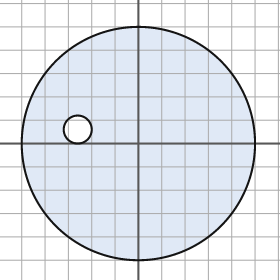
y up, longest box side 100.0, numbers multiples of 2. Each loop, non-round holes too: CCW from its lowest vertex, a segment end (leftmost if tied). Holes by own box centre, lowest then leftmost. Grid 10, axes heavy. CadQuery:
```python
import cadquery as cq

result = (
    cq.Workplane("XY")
    .moveTo(0.0, 0.0)
    .circle(50.0)
    .moveTo(-26.0, 6.0)
    .circle(6.0)
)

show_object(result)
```